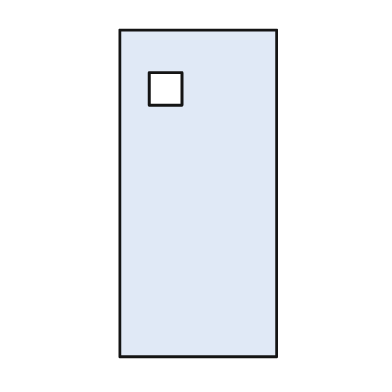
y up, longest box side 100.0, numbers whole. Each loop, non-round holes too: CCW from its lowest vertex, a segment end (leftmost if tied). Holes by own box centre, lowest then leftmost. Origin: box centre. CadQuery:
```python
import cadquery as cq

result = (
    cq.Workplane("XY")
    .moveTo(-24.0, -50.0)
    .lineTo(24.0, -50.0)
    .lineTo(24.0, 50.0)
    .lineTo(-24.0, 50.0)
    .close()
    .moveTo(-15.0, 27.0)
    .lineTo(-5.0, 27.0)
    .lineTo(-5.0, 37.0)
    .lineTo(-15.0, 37.0)
    .close()
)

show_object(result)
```